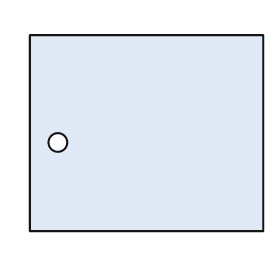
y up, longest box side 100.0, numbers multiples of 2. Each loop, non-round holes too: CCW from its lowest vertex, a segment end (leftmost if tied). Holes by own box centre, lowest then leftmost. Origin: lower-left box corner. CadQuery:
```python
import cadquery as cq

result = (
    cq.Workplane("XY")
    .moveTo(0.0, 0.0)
    .lineTo(100.0, 0.0)
    .lineTo(100.0, 84.0)
    .lineTo(0.0, 84.0)
    .close()
    .moveTo(12.0, 38.0)
    .circle(4.0)
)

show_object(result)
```